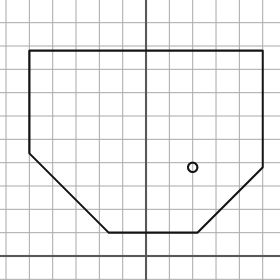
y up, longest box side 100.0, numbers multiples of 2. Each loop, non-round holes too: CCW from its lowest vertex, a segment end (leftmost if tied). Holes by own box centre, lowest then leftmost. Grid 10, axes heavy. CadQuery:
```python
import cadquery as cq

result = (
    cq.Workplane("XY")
    .moveTo(-16.0, 10.0)
    .lineTo(22.0, 10.0)
    .lineTo(50.0, 38.0)
    .lineTo(50.0, 88.0)
    .lineTo(-50.0, 88.0)
    .lineTo(-50.0, 44.0)
    .close()
    .moveTo(20.0, 38.0)
    .circle(2.0)
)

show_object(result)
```